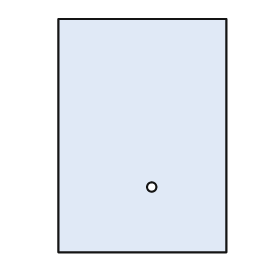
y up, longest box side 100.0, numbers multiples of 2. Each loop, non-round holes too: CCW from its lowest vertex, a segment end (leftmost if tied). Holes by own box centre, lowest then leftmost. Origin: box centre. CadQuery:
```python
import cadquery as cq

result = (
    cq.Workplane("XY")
    .moveTo(-36.0, -50.0)
    .lineTo(36.0, -50.0)
    .lineTo(36.0, 50.0)
    .lineTo(-36.0, 50.0)
    .close()
    .moveTo(4.0, -22.0)
    .circle(2.0)
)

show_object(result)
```